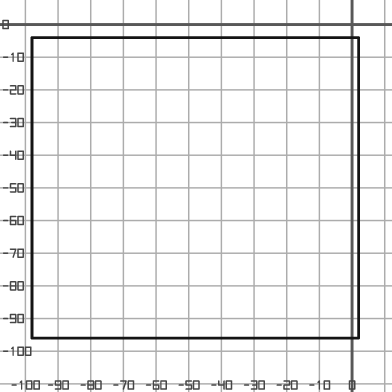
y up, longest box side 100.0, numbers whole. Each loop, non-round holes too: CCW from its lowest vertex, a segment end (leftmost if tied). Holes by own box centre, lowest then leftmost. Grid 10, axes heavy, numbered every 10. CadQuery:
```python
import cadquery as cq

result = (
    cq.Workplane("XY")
    .moveTo(-98.0, -96.0)
    .lineTo(2.0, -96.0)
    .lineTo(2.0, -4.0)
    .lineTo(-98.0, -4.0)
    .close()
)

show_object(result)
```